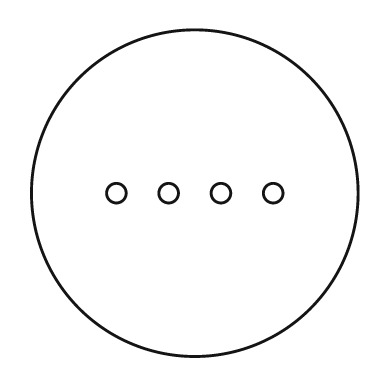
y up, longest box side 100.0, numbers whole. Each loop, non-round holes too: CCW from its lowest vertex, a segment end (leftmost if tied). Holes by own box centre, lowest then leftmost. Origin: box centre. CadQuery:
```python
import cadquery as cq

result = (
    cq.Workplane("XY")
    .moveTo(0.0, 0.0)
    .circle(50.0)
    .moveTo(-24.0, 0.0)
    .circle(3.0)
    .moveTo(-8.0, 0.0)
    .circle(3.0)
    .moveTo(8.0, 0.0)
    .circle(3.0)
    .moveTo(24.0, 0.0)
    .circle(3.0)
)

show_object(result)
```